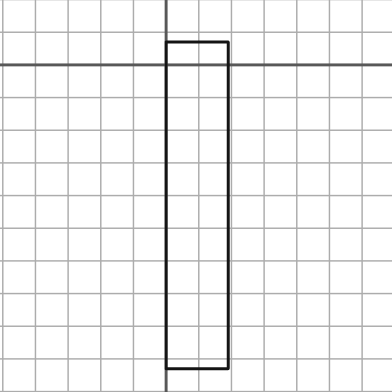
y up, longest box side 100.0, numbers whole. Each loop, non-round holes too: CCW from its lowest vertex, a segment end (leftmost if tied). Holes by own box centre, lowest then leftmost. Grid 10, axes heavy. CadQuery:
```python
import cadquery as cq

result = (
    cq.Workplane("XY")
    .moveTo(0.0, -93.0)
    .lineTo(19.0, -93.0)
    .lineTo(19.0, 7.0)
    .lineTo(0.0, 7.0)
    .close()
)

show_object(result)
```